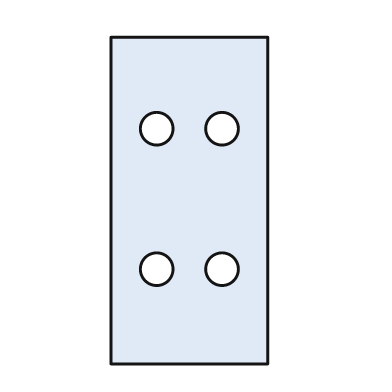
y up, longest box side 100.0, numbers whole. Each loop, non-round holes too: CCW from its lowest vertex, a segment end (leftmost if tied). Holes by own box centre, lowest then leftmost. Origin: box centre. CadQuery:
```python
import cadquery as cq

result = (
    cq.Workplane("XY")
    .moveTo(-24.0, -50.0)
    .lineTo(24.0, -50.0)
    .lineTo(24.0, 50.0)
    .lineTo(-24.0, 50.0)
    .close()
    .moveTo(-10.0, -21.0)
    .circle(5.0)
    .moveTo(10.0, -21.0)
    .circle(5.0)
    .moveTo(-10.0, 22.0)
    .circle(5.0)
    .moveTo(10.0, 22.0)
    .circle(5.0)
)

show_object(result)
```